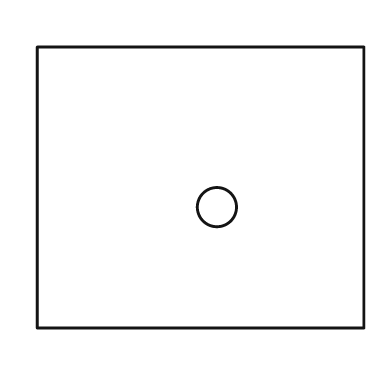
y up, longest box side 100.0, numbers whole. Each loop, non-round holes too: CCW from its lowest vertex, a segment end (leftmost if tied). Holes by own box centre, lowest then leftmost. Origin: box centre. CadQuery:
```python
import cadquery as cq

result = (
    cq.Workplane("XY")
    .moveTo(-50.0, -43.0)
    .lineTo(50.0, -43.0)
    .lineTo(50.0, 43.0)
    .lineTo(-50.0, 43.0)
    .close()
    .moveTo(5.0, -6.0)
    .circle(6.0)
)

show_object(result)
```